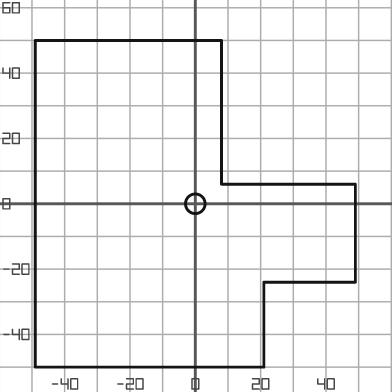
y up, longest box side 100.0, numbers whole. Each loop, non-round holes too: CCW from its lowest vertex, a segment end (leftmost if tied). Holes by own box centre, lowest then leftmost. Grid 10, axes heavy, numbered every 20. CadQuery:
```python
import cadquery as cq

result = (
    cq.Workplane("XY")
    .moveTo(-49.0, -50.0)
    .lineTo(21.0, -50.0)
    .lineTo(21.0, -24.0)
    .lineTo(49.0, -24.0)
    .lineTo(49.0, 6.0)
    .lineTo(8.0, 6.0)
    .lineTo(8.0, 50.0)
    .lineTo(-49.0, 50.0)
    .close()
    .moveTo(0.0, 0.0)
    .circle(3.0)
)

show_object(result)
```